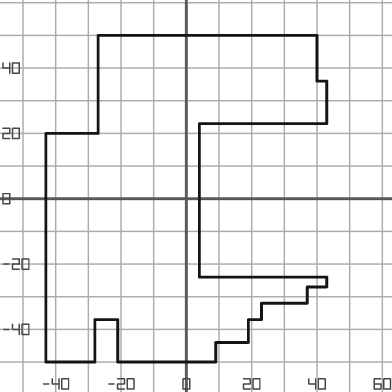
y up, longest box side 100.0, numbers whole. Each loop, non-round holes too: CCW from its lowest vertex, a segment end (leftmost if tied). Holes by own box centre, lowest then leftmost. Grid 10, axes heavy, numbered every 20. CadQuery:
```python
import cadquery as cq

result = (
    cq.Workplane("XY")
    .moveTo(-43.0, -50.0)
    .lineTo(-28.0, -50.0)
    .lineTo(-28.0, -37.0)
    .lineTo(-21.0, -37.0)
    .lineTo(-21.0, -50.0)
    .lineTo(9.0, -50.0)
    .lineTo(9.0, -44.0)
    .lineTo(19.0, -44.0)
    .lineTo(19.0, -37.0)
    .lineTo(23.0, -37.0)
    .lineTo(23.0, -32.0)
    .lineTo(37.0, -32.0)
    .lineTo(37.0, -27.0)
    .lineTo(43.0, -27.0)
    .lineTo(43.0, -24.0)
    .lineTo(4.0, -24.0)
    .lineTo(4.0, 23.0)
    .lineTo(43.0, 23.0)
    .lineTo(43.0, 36.0)
    .lineTo(40.0, 36.0)
    .lineTo(40.0, 50.0)
    .lineTo(-27.0, 50.0)
    .lineTo(-27.0, 20.0)
    .lineTo(-43.0, 20.0)
    .close()
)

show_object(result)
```